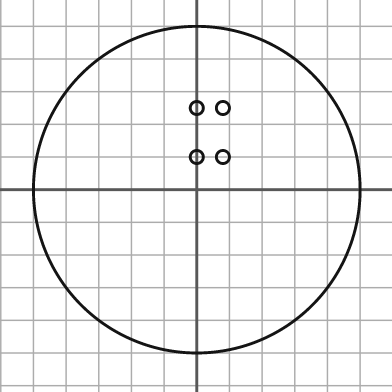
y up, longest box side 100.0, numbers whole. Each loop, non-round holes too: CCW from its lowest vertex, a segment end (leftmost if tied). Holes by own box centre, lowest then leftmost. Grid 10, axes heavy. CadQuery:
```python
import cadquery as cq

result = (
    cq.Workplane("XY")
    .moveTo(0.0, 0.0)
    .circle(50.0)
    .moveTo(0.0, 10.0)
    .circle(2.0)
    .moveTo(8.0, 10.0)
    .circle(2.0)
    .moveTo(0.0, 25.0)
    .circle(2.0)
    .moveTo(8.0, 25.0)
    .circle(2.0)
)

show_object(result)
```